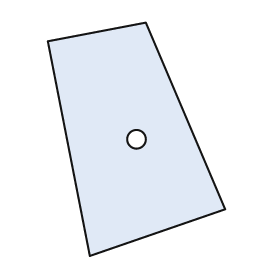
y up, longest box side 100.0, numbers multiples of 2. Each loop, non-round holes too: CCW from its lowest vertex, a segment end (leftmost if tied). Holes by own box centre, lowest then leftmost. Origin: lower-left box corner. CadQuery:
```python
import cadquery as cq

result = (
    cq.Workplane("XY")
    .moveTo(18.0, 0.0)
    .lineTo(76.0, 20.0)
    .lineTo(42.0, 100.0)
    .lineTo(0.0, 92.0)
    .close()
    .moveTo(38.0, 50.0)
    .circle(4.0)
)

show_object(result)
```